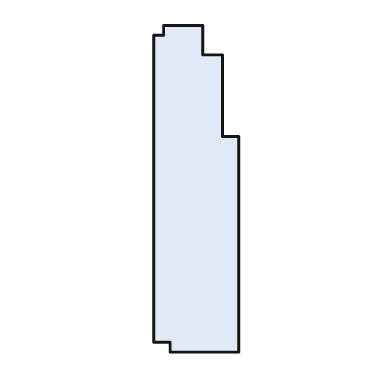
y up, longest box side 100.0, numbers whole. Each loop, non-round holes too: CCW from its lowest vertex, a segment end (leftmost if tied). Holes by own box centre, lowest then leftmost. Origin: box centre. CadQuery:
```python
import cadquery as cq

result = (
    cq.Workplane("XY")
    .moveTo(-8.0, -50.0)
    .lineTo(13.0, -50.0)
    .lineTo(13.0, 16.0)
    .lineTo(8.0, 16.0)
    .lineTo(8.0, 41.0)
    .lineTo(2.0, 41.0)
    .lineTo(2.0, 50.0)
    .lineTo(-10.0, 50.0)
    .lineTo(-10.0, 47.0)
    .lineTo(-13.0, 47.0)
    .lineTo(-13.0, -47.0)
    .lineTo(-8.0, -47.0)
    .close()
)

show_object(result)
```